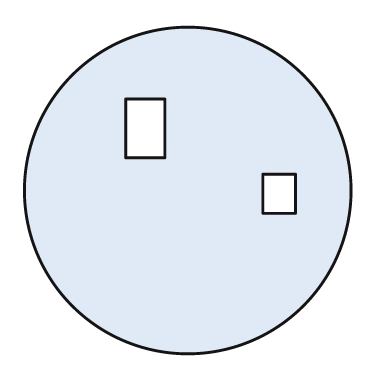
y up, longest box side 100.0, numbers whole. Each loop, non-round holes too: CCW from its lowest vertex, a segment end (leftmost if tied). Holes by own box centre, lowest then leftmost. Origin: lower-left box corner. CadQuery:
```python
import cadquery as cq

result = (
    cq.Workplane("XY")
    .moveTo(50.0, 50.0)
    .circle(50.0)
    .moveTo(73.0, 43.0)
    .lineTo(83.0, 43.0)
    .lineTo(83.0, 55.0)
    .lineTo(73.0, 55.0)
    .close()
    .moveTo(31.0, 60.0)
    .lineTo(43.0, 60.0)
    .lineTo(43.0, 78.0)
    .lineTo(31.0, 78.0)
    .close()
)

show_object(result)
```